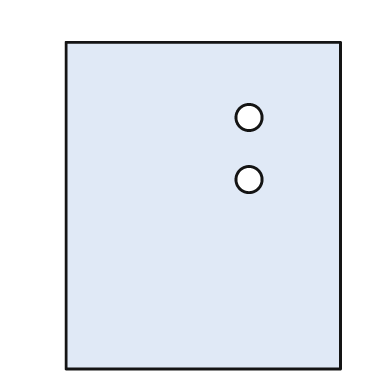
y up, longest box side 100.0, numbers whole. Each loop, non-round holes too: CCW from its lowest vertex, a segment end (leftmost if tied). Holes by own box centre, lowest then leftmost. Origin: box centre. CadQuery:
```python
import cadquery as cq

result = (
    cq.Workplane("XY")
    .moveTo(-42.0, -50.0)
    .lineTo(42.0, -50.0)
    .lineTo(42.0, 50.0)
    .lineTo(-42.0, 50.0)
    .close()
    .moveTo(14.0, 8.0)
    .circle(4.0)
    .moveTo(14.0, 27.0)
    .circle(4.0)
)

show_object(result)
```